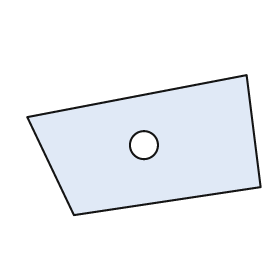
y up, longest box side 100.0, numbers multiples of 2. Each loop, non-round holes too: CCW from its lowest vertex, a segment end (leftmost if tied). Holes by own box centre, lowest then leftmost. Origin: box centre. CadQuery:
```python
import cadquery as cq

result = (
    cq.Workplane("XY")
    .moveTo(-30.0, -30.0)
    .lineTo(50.0, -18.0)
    .lineTo(44.0, 30.0)
    .lineTo(-50.0, 12.0)
    .close()
    .moveTo(0.0, 0.0)
    .circle(6.0)
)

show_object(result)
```